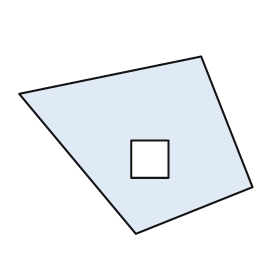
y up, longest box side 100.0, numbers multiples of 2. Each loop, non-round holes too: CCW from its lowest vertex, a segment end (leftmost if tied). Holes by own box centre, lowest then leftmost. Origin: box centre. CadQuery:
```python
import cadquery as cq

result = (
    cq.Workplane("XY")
    .moveTo(0.0, -38.0)
    .lineTo(50.0, -18.0)
    .lineTo(28.0, 38.0)
    .lineTo(-50.0, 22.0)
    .close()
    .moveTo(-2.0, -14.0)
    .lineTo(14.0, -14.0)
    .lineTo(14.0, 2.0)
    .lineTo(-2.0, 2.0)
    .close()
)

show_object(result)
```